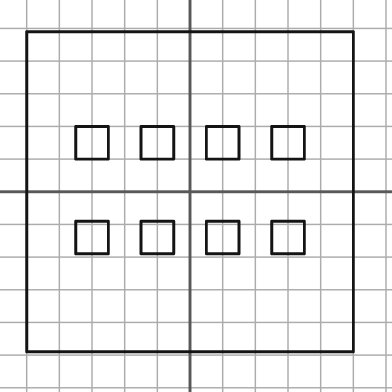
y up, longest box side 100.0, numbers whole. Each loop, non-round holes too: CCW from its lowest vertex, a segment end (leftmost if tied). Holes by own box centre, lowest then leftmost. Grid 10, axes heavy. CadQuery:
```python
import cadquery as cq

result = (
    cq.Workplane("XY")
    .moveTo(-50.0, -49.0)
    .lineTo(50.0, -49.0)
    .lineTo(50.0, 49.0)
    .lineTo(-50.0, 49.0)
    .close()
    .moveTo(-35.0, -19.0)
    .lineTo(-25.0, -19.0)
    .lineTo(-25.0, -9.0)
    .lineTo(-35.0, -9.0)
    .close()
    .moveTo(-15.0, -19.0)
    .lineTo(-5.0, -19.0)
    .lineTo(-5.0, -9.0)
    .lineTo(-15.0, -9.0)
    .close()
    .moveTo(5.0, -19.0)
    .lineTo(15.0, -19.0)
    .lineTo(15.0, -9.0)
    .lineTo(5.0, -9.0)
    .close()
    .moveTo(25.0, -19.0)
    .lineTo(35.0, -19.0)
    .lineTo(35.0, -9.0)
    .lineTo(25.0, -9.0)
    .close()
    .moveTo(-35.0, 10.0)
    .lineTo(-25.0, 10.0)
    .lineTo(-25.0, 20.0)
    .lineTo(-35.0, 20.0)
    .close()
    .moveTo(-15.0, 10.0)
    .lineTo(-5.0, 10.0)
    .lineTo(-5.0, 20.0)
    .lineTo(-15.0, 20.0)
    .close()
    .moveTo(5.0, 10.0)
    .lineTo(15.0, 10.0)
    .lineTo(15.0, 20.0)
    .lineTo(5.0, 20.0)
    .close()
    .moveTo(25.0, 10.0)
    .lineTo(35.0, 10.0)
    .lineTo(35.0, 20.0)
    .lineTo(25.0, 20.0)
    .close()
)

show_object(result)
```